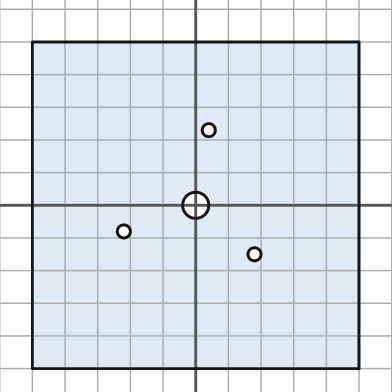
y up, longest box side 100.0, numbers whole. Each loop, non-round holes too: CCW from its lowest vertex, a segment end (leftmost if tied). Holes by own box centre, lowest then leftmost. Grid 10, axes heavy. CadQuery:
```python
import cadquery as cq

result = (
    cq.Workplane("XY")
    .moveTo(-50.0, -50.0)
    .lineTo(50.0, -50.0)
    .lineTo(50.0, 50.0)
    .lineTo(-50.0, 50.0)
    .close()
    .moveTo(18.0, -15.0)
    .circle(2.0)
    .moveTo(-22.0, -8.0)
    .circle(2.0)
    .moveTo(0.0, 0.0)
    .circle(4.0)
    .moveTo(4.0, 23.0)
    .circle(2.0)
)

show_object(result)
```